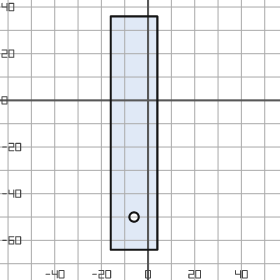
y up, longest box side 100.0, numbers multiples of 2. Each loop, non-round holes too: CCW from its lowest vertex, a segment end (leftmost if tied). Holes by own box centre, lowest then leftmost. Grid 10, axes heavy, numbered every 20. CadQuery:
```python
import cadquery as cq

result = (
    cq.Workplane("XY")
    .moveTo(-16.0, -64.0)
    .lineTo(4.0, -64.0)
    .lineTo(4.0, 36.0)
    .lineTo(-16.0, 36.0)
    .close()
    .moveTo(-6.0, -50.0)
    .circle(2.0)
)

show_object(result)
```